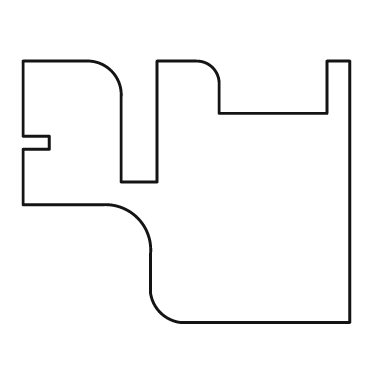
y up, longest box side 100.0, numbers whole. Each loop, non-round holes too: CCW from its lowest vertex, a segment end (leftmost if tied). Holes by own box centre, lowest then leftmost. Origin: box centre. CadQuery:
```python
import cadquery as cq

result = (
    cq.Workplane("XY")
    .moveTo(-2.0, -40.0)
    .lineTo(50.0, -40.0)
    .lineTo(50.0, 40.0)
    .lineTo(43.0, 40.0)
    .lineTo(43.0, 24.0)
    .lineTo(10.0, 24.0)
    .lineTo(10.0, 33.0)
    .threePointArc((8.0, 38.0), (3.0, 40.0))
    .lineTo(-9.0, 40.0)
    .lineTo(-9.0, 3.0)
    .lineTo(-20.0, 3.0)
    .lineTo(-20.0, 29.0)
    .threePointArc((-23.0, 37.0), (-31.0, 40.0))
    .lineTo(-50.0, 40.0)
    .lineTo(-50.0, 17.0)
    .lineTo(-42.0, 17.0)
    .lineTo(-42.0, 13.0)
    .lineTo(-50.0, 13.0)
    .lineTo(-50.0, -4.0)
    .lineTo(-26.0, -4.0)
    .threePointArc((-15.0, -8.0), (-11.0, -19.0))
    .lineTo(-11.0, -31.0)
    .threePointArc((-8.0, -37.0), (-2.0, -40.0))
    .close()
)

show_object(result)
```